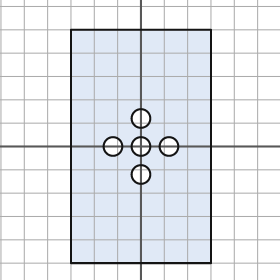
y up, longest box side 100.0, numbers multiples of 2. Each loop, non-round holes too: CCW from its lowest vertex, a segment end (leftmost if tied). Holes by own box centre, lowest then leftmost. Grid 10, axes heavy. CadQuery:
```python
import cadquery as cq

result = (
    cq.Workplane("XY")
    .moveTo(-30.0, -50.0)
    .lineTo(30.0, -50.0)
    .lineTo(30.0, 50.0)
    .lineTo(-30.0, 50.0)
    .close()
    .moveTo(0.0, -12.0)
    .circle(4.0)
    .moveTo(-12.0, 0.0)
    .circle(4.0)
    .moveTo(0.0, 0.0)
    .circle(4.0)
    .moveTo(12.0, 0.0)
    .circle(4.0)
    .moveTo(0.0, 12.0)
    .circle(4.0)
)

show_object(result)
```